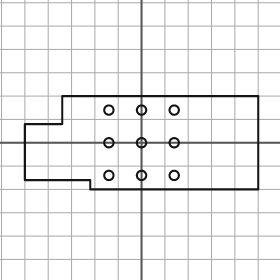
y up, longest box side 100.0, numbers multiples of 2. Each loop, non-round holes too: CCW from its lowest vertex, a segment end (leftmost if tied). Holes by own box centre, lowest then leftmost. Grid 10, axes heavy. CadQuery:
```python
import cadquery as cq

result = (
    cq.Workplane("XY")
    .moveTo(-22.0, -20.0)
    .lineTo(50.0, -20.0)
    .lineTo(50.0, 20.0)
    .lineTo(-34.0, 20.0)
    .lineTo(-34.0, 8.0)
    .lineTo(-50.0, 8.0)
    .lineTo(-50.0, -16.0)
    .lineTo(-22.0, -16.0)
    .close()
    .moveTo(-14.0, -14.0)
    .circle(2.0)
    .moveTo(0.0, -14.0)
    .circle(2.0)
    .moveTo(14.0, -14.0)
    .circle(2.0)
    .moveTo(-14.0, 0.0)
    .circle(2.0)
    .moveTo(0.0, 0.0)
    .circle(2.0)
    .moveTo(14.0, 0.0)
    .circle(2.0)
    .moveTo(-14.0, 14.0)
    .circle(2.0)
    .moveTo(0.0, 14.0)
    .circle(2.0)
    .moveTo(14.0, 14.0)
    .circle(2.0)
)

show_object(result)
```